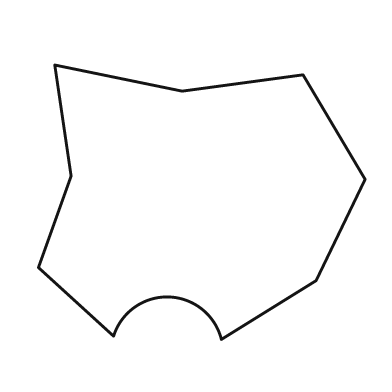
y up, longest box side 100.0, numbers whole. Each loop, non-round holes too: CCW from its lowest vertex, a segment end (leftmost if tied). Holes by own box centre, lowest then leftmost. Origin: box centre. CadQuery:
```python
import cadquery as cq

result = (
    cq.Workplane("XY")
    .moveTo(6.0, -42.0)
    .lineTo(35.0, -24.0)
    .lineTo(50.0, 7.0)
    .lineTo(31.0, 39.0)
    .lineTo(-6.0, 34.0)
    .lineTo(-45.0, 42.0)
    .lineTo(-40.0, 8.0)
    .lineTo(-50.0, -20.0)
    .lineTo(-27.0, -41.0)
    .threePointArc((-10.0, -29.0), (6.0, -42.0))
    .close()
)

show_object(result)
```